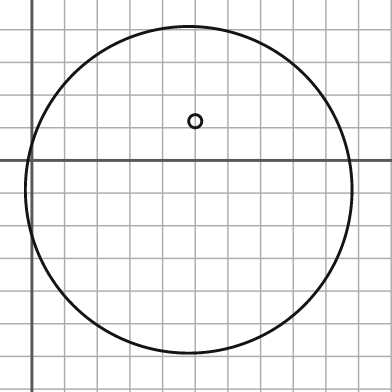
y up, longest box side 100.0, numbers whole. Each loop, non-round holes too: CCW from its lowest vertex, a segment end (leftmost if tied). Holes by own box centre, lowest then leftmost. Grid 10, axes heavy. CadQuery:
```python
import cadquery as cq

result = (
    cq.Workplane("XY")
    .moveTo(48.0, -9.0)
    .circle(50.0)
    .moveTo(50.0, 12.0)
    .circle(2.0)
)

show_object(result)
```